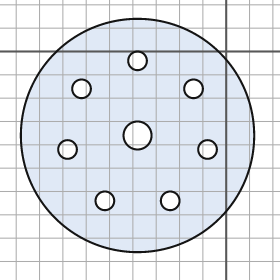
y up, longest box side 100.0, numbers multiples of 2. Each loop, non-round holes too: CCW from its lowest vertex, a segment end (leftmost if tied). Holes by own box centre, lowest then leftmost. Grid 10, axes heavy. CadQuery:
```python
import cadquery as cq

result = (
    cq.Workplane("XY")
    .moveTo(-38.0, -36.0)
    .circle(50.0)
    .moveTo(-52.0, -64.0)
    .circle(4.0)
    .moveTo(-24.0, -64.0)
    .circle(4.0)
    .moveTo(-68.0, -42.0)
    .circle(4.0)
    .moveTo(-8.0, -42.0)
    .circle(4.0)
    .moveTo(-38.0, -36.0)
    .circle(6.0)
    .moveTo(-62.0, -16.0)
    .circle(4.0)
    .moveTo(-14.0, -16.0)
    .circle(4.0)
    .moveTo(-38.0, -4.0)
    .circle(4.0)
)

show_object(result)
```